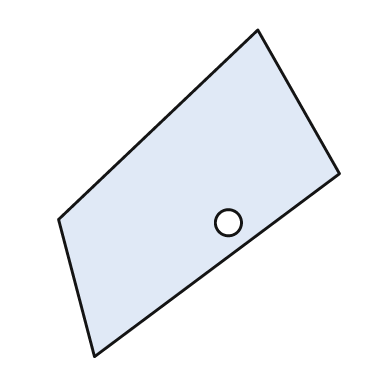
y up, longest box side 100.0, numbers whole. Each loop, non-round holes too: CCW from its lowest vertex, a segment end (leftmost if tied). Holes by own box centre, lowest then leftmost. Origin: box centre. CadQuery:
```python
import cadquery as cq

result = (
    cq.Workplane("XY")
    .moveTo(-32.0, -50.0)
    .lineTo(43.0, 6.0)
    .lineTo(18.0, 50.0)
    .lineTo(-43.0, -8.0)
    .close()
    .moveTo(9.0, -9.0)
    .circle(4.0)
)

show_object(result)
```